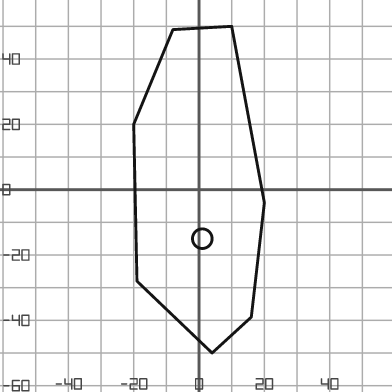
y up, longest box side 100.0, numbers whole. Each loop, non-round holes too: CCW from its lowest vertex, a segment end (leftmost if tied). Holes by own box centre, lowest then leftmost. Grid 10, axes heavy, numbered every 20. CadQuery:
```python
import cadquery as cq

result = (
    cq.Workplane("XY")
    .moveTo(4.0, -50.0)
    .lineTo(16.0, -39.0)
    .lineTo(20.0, -4.0)
    .lineTo(10.0, 50.0)
    .lineTo(-8.0, 49.0)
    .lineTo(-20.0, 20.0)
    .lineTo(-19.0, -28.0)
    .close()
    .moveTo(1.0, -15.0)
    .circle(3.0)
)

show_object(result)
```